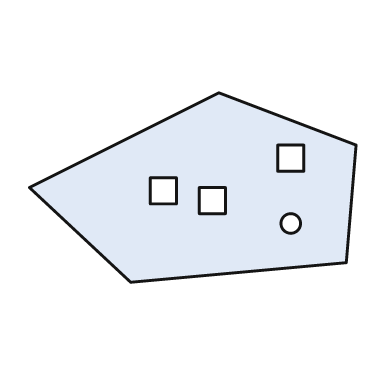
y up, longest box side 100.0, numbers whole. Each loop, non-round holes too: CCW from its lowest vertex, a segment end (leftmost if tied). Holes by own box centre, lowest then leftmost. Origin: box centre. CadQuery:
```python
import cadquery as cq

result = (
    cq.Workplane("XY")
    .moveTo(-19.0, -29.0)
    .lineTo(47.0, -23.0)
    .lineTo(50.0, 13.0)
    .lineTo(8.0, 29.0)
    .lineTo(-50.0, 0.0)
    .close()
    .moveTo(30.0, -11.0)
    .circle(3.0)
    .moveTo(2.0, -8.0)
    .lineTo(10.0, -8.0)
    .lineTo(10.0, 0.0)
    .lineTo(2.0, 0.0)
    .close()
    .moveTo(-13.0, -5.0)
    .lineTo(-5.0, -5.0)
    .lineTo(-5.0, 3.0)
    .lineTo(-13.0, 3.0)
    .close()
    .moveTo(26.0, 5.0)
    .lineTo(34.0, 5.0)
    .lineTo(34.0, 13.0)
    .lineTo(26.0, 13.0)
    .close()
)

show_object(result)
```